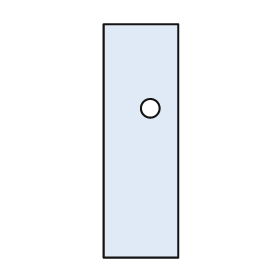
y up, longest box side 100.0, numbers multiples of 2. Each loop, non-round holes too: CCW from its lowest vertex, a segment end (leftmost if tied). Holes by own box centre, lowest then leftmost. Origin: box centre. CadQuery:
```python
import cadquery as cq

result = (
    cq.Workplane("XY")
    .moveTo(-16.0, -50.0)
    .lineTo(16.0, -50.0)
    .lineTo(16.0, 50.0)
    .lineTo(-16.0, 50.0)
    .close()
    .moveTo(4.0, 14.0)
    .circle(4.0)
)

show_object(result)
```